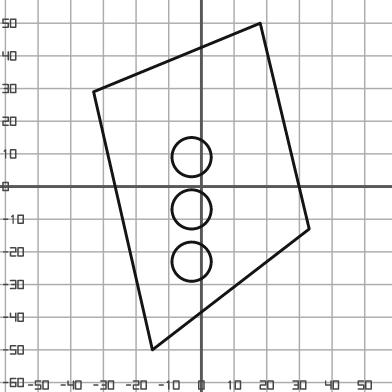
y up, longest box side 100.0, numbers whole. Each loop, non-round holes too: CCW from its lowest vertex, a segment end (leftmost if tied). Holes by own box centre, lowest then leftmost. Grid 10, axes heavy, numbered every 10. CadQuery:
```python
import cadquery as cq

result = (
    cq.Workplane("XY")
    .moveTo(-15.0, -50.0)
    .lineTo(33.0, -13.0)
    .lineTo(18.0, 50.0)
    .lineTo(-33.0, 29.0)
    .close()
    .moveTo(-3.0, -23.0)
    .circle(6.0)
    .moveTo(-3.0, -7.0)
    .circle(6.0)
    .moveTo(-3.0, 9.0)
    .circle(6.0)
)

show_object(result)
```